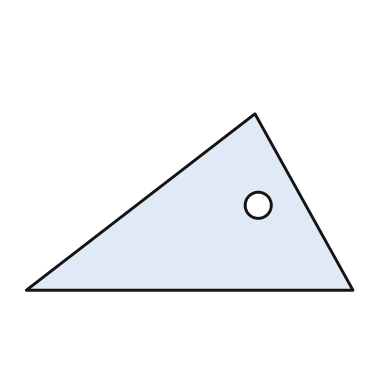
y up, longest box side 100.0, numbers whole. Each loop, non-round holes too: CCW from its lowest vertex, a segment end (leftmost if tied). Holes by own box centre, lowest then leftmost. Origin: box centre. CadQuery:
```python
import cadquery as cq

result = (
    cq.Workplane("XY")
    .moveTo(-50.0, -27.0)
    .lineTo(50.0, -27.0)
    .lineTo(20.0, 27.0)
    .close()
    .moveTo(21.0, -1.0)
    .circle(4.0)
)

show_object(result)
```